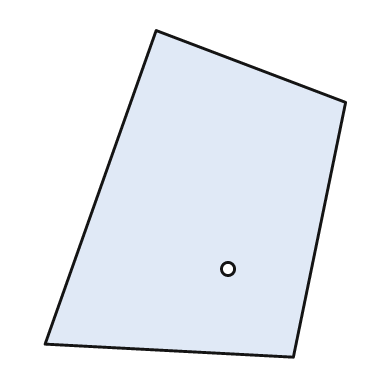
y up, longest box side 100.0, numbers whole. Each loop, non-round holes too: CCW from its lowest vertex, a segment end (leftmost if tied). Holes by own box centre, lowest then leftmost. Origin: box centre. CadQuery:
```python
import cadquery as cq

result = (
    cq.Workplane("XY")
    .moveTo(30.0, -50.0)
    .lineTo(46.0, 28.0)
    .lineTo(-12.0, 50.0)
    .lineTo(-46.0, -46.0)
    .close()
    .moveTo(10.0, -23.0)
    .circle(2.0)
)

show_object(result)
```